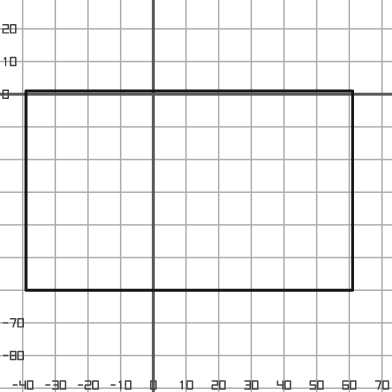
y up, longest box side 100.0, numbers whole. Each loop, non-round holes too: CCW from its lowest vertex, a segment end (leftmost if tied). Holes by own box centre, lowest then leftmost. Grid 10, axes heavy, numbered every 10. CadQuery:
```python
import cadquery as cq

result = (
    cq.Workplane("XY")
    .moveTo(-39.0, -60.0)
    .lineTo(61.0, -60.0)
    .lineTo(61.0, 1.0)
    .lineTo(-39.0, 1.0)
    .close()
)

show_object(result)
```